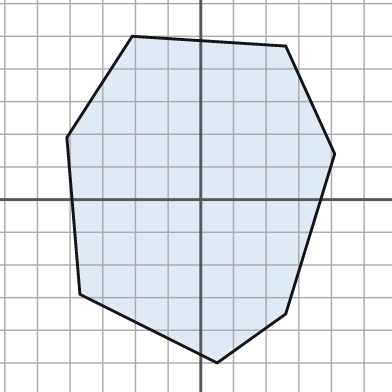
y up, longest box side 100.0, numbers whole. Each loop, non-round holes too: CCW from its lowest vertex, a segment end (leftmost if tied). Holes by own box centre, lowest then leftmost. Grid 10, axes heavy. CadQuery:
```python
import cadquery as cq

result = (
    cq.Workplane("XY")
    .moveTo(5.0, -50.0)
    .lineTo(26.0, -35.0)
    .lineTo(41.0, 14.0)
    .lineTo(26.0, 47.0)
    .lineTo(-21.0, 50.0)
    .lineTo(-41.0, 19.0)
    .lineTo(-37.0, -29.0)
    .close()
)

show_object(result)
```